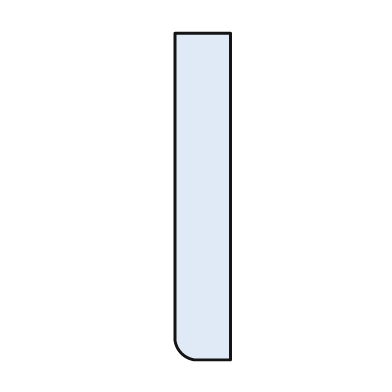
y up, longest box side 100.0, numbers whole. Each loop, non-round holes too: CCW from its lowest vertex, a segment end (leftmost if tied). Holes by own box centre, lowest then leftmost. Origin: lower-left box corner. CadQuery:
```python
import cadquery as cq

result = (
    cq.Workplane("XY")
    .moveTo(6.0, 0.0)
    .lineTo(17.0, 0.0)
    .lineTo(17.0, 100.0)
    .lineTo(0.0, 100.0)
    .lineTo(0.0, 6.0)
    .threePointArc((2.0, 2.0), (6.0, 0.0))
    .close()
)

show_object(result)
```